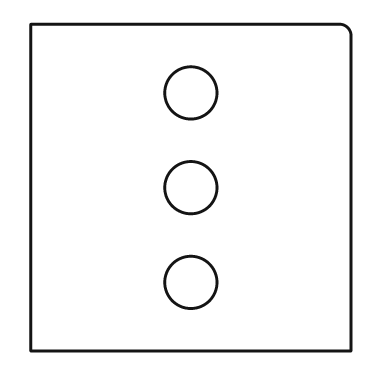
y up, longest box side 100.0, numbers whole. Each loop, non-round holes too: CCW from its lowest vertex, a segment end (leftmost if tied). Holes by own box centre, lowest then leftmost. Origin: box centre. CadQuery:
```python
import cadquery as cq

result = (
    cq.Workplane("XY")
    .moveTo(-49.0, -50.0)
    .lineTo(49.0, -50.0)
    .lineTo(49.0, 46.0)
    .threePointArc((48.0, 49.0), (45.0, 50.0))
    .lineTo(-49.0, 50.0)
    .close()
    .moveTo(0.0, -29.0)
    .circle(8.0)
    .moveTo(0.0, 0.0)
    .circle(8.0)
    .moveTo(0.0, 29.0)
    .circle(8.0)
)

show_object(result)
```